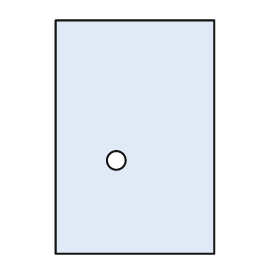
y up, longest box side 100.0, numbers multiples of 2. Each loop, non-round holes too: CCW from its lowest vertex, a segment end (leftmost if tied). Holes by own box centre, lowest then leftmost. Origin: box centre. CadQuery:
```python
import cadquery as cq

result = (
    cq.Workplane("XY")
    .moveTo(-34.0, -50.0)
    .lineTo(34.0, -50.0)
    .lineTo(34.0, 50.0)
    .lineTo(-34.0, 50.0)
    .close()
    .moveTo(-8.0, -10.0)
    .circle(4.0)
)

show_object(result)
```